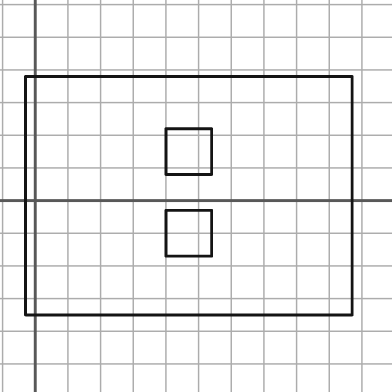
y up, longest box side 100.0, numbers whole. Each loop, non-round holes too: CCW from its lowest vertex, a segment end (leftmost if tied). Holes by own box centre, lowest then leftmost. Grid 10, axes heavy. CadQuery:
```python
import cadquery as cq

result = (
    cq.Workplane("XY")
    .moveTo(-3.0, -35.0)
    .lineTo(97.0, -35.0)
    .lineTo(97.0, 38.0)
    .lineTo(-3.0, 38.0)
    .close()
    .moveTo(40.0, -17.0)
    .lineTo(54.0, -17.0)
    .lineTo(54.0, -3.0)
    .lineTo(40.0, -3.0)
    .close()
    .moveTo(40.0, 8.0)
    .lineTo(54.0, 8.0)
    .lineTo(54.0, 22.0)
    .lineTo(40.0, 22.0)
    .close()
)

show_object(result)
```